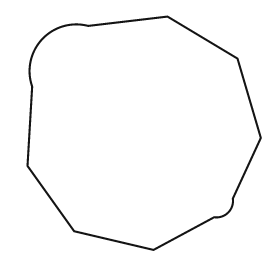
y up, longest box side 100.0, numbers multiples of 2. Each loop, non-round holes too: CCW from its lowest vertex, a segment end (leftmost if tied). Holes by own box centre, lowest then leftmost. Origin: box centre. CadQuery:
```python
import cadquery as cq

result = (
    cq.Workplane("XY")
    .moveTo(4.0, -50.0)
    .lineTo(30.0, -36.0)
    .threePointArc((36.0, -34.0), (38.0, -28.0))
    .lineTo(50.0, -2.0)
    .lineTo(40.0, 32.0)
    .lineTo(10.0, 50.0)
    .lineTo(-24.0, 46.0)
    .threePointArc((-44.0, 40.0), (-48.0, 20.0))
    .lineTo(-50.0, -14.0)
    .lineTo(-30.0, -42.0)
    .close()
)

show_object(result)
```